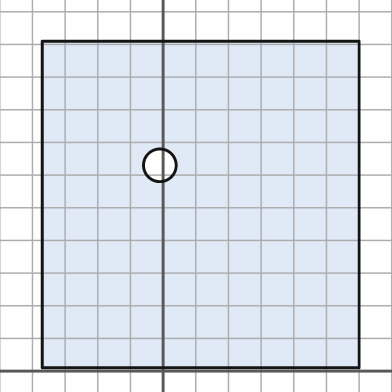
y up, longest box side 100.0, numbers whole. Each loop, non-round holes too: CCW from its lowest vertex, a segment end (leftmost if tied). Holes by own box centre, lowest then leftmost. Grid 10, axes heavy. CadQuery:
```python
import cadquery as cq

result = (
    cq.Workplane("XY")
    .moveTo(-37.0, 1.0)
    .lineTo(60.0, 1.0)
    .lineTo(60.0, 101.0)
    .lineTo(-37.0, 101.0)
    .close()
    .moveTo(-1.0, 63.0)
    .circle(5.0)
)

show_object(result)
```